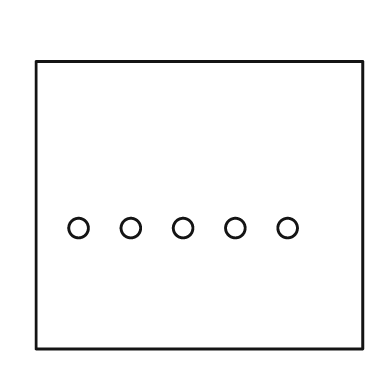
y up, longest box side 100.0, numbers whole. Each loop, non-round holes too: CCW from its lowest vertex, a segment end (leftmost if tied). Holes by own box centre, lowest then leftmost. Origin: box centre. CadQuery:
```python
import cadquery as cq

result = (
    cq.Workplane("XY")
    .moveTo(-50.0, -44.0)
    .lineTo(50.0, -44.0)
    .lineTo(50.0, 44.0)
    .lineTo(-50.0, 44.0)
    .close()
    .moveTo(-37.0, -7.0)
    .circle(3.0)
    .moveTo(-21.0, -7.0)
    .circle(3.0)
    .moveTo(-5.0, -7.0)
    .circle(3.0)
    .moveTo(11.0, -7.0)
    .circle(3.0)
    .moveTo(27.0, -7.0)
    .circle(3.0)
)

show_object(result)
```